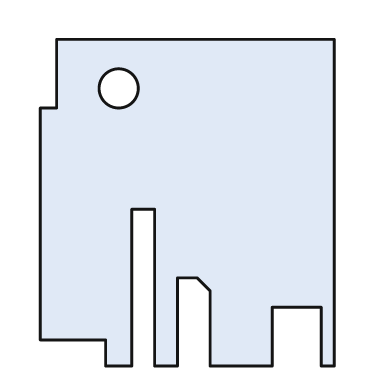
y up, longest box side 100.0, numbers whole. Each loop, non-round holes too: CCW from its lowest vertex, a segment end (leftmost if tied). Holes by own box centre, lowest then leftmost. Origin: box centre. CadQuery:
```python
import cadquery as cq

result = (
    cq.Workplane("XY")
    .moveTo(-25.0, -50.0)
    .lineTo(-17.0, -50.0)
    .lineTo(-17.0, -2.0)
    .lineTo(-10.0, -2.0)
    .lineTo(-10.0, -50.0)
    .lineTo(-3.0, -50.0)
    .lineTo(-3.0, -23.0)
    .lineTo(3.0, -23.0)
    .lineTo(7.0, -27.0)
    .lineTo(7.0, -50.0)
    .lineTo(26.0, -50.0)
    .lineTo(26.0, -32.0)
    .lineTo(41.0, -32.0)
    .lineTo(41.0, -50.0)
    .lineTo(45.0, -50.0)
    .lineTo(45.0, 50.0)
    .lineTo(-40.0, 50.0)
    .lineTo(-40.0, 29.0)
    .lineTo(-45.0, 29.0)
    .lineTo(-45.0, -42.0)
    .lineTo(-25.0, -42.0)
    .close()
    .moveTo(-21.0, 35.0)
    .circle(6.0)
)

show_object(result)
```